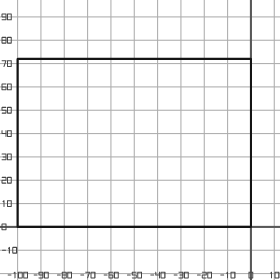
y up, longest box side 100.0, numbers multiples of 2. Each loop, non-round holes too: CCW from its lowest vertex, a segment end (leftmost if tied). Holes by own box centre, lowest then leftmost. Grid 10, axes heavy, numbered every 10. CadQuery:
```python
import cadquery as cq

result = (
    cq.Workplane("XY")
    .moveTo(-100.0, 0.0)
    .lineTo(0.0, 0.0)
    .lineTo(0.0, 72.0)
    .lineTo(-100.0, 72.0)
    .close()
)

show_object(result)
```